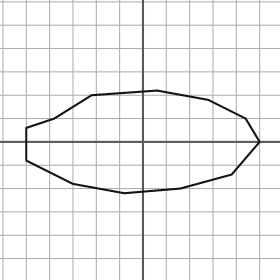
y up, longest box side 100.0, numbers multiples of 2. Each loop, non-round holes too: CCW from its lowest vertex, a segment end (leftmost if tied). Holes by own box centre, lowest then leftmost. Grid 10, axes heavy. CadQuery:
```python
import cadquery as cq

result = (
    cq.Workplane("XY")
    .moveTo(-8.0, -22.0)
    .lineTo(16.0, -20.0)
    .lineTo(38.0, -14.0)
    .lineTo(50.0, 0.0)
    .lineTo(44.0, 10.0)
    .lineTo(28.0, 18.0)
    .lineTo(6.0, 22.0)
    .lineTo(-22.0, 20.0)
    .lineTo(-38.0, 10.0)
    .lineTo(-50.0, 6.0)
    .lineTo(-50.0, -8.0)
    .lineTo(-30.0, -18.0)
    .close()
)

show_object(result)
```